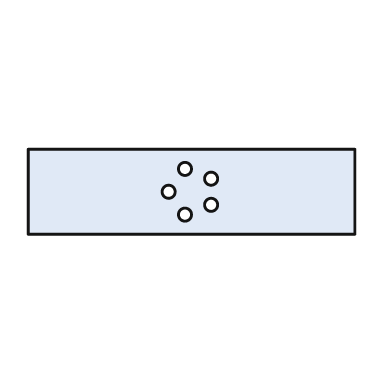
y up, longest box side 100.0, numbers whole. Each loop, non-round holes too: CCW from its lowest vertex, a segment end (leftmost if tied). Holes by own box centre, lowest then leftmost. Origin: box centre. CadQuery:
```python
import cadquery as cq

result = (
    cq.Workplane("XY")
    .moveTo(-50.0, -13.0)
    .lineTo(50.0, -13.0)
    .lineTo(50.0, 13.0)
    .lineTo(-50.0, 13.0)
    .close()
    .moveTo(-2.0, -7.0)
    .circle(2.0)
    .moveTo(6.0, -4.0)
    .circle(2.0)
    .moveTo(-7.0, 0.0)
    .circle(2.0)
    .moveTo(6.0, 4.0)
    .circle(2.0)
    .moveTo(-2.0, 7.0)
    .circle(2.0)
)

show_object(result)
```